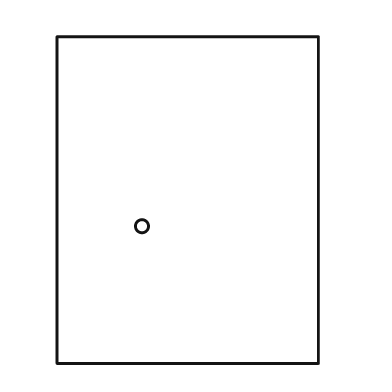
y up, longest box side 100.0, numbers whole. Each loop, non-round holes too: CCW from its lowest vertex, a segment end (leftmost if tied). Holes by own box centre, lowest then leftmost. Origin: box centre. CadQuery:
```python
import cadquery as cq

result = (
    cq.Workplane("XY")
    .moveTo(-40.0, -50.0)
    .lineTo(40.0, -50.0)
    .lineTo(40.0, 50.0)
    .lineTo(-40.0, 50.0)
    .close()
    .moveTo(-14.0, -8.0)
    .circle(2.0)
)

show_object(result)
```